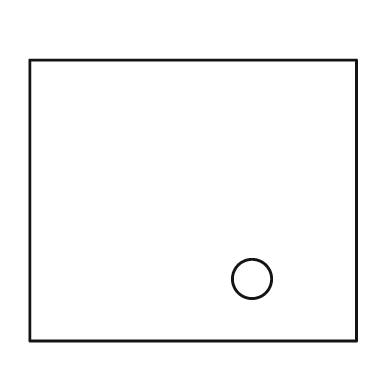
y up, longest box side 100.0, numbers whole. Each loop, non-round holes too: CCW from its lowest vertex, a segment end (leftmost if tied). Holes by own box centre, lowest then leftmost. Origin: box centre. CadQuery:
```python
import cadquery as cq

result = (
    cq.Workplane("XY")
    .moveTo(-50.0, -43.0)
    .lineTo(50.0, -43.0)
    .lineTo(50.0, 43.0)
    .lineTo(-50.0, 43.0)
    .close()
    .moveTo(18.0, -24.0)
    .circle(6.0)
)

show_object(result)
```